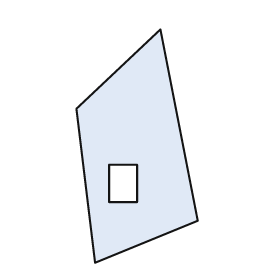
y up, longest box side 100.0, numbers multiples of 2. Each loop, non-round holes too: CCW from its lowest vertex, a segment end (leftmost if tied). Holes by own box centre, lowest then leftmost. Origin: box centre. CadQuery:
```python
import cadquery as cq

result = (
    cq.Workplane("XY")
    .moveTo(-18.0, -50.0)
    .lineTo(26.0, -32.0)
    .lineTo(10.0, 50.0)
    .lineTo(-26.0, 16.0)
    .close()
    .moveTo(-12.0, -24.0)
    .lineTo(0.0, -24.0)
    .lineTo(0.0, -8.0)
    .lineTo(-12.0, -8.0)
    .close()
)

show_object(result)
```